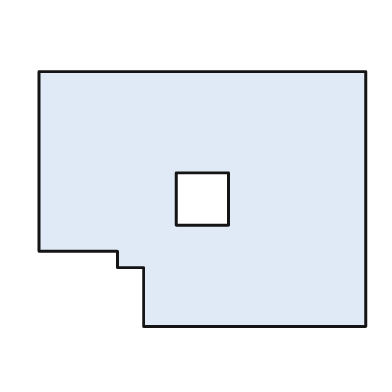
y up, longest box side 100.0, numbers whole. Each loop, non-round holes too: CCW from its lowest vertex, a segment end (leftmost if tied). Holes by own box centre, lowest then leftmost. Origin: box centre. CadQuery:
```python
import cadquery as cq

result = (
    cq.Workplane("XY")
    .moveTo(-18.0, -39.0)
    .lineTo(50.0, -39.0)
    .lineTo(50.0, 39.0)
    .lineTo(-50.0, 39.0)
    .lineTo(-50.0, -16.0)
    .lineTo(-26.0, -16.0)
    .lineTo(-26.0, -21.0)
    .lineTo(-18.0, -21.0)
    .close()
    .moveTo(-8.0, -8.0)
    .lineTo(8.0, -8.0)
    .lineTo(8.0, 8.0)
    .lineTo(-8.0, 8.0)
    .close()
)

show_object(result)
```